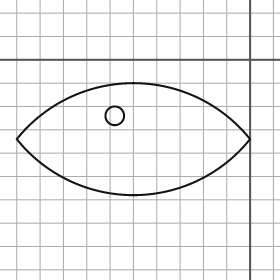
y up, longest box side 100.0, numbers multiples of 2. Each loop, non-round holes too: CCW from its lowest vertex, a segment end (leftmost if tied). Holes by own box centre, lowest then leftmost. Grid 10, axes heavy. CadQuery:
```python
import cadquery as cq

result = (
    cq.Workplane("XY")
    .moveTo(-100.0, -34.0)
    .threePointArc((-50.0, -58.0), (0.0, -34.0))
    .threePointArc((-50.0, -10.0), (-100.0, -34.0))
    .close()
    .moveTo(-58.0, -24.0)
    .circle(4.0)
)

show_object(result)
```